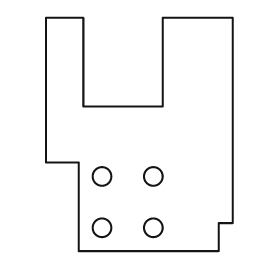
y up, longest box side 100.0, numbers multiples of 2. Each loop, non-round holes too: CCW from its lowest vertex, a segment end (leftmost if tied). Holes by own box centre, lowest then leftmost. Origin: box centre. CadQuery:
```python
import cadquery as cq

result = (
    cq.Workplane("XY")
    .moveTo(-26.0, -50.0)
    .lineTo(34.0, -50.0)
    .lineTo(34.0, -38.0)
    .lineTo(40.0, -38.0)
    .lineTo(40.0, 50.0)
    .lineTo(10.0, 50.0)
    .lineTo(10.0, 12.0)
    .lineTo(-24.0, 12.0)
    .lineTo(-24.0, 50.0)
    .lineTo(-40.0, 50.0)
    .lineTo(-40.0, -12.0)
    .lineTo(-26.0, -12.0)
    .close()
    .moveTo(-16.0, -40.0)
    .circle(4.0)
    .moveTo(6.0, -40.0)
    .circle(4.0)
    .moveTo(-16.0, -18.0)
    .circle(4.0)
    .moveTo(6.0, -18.0)
    .circle(4.0)
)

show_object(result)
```